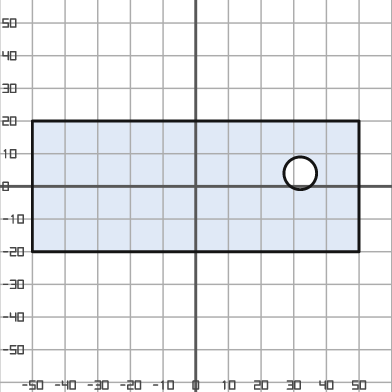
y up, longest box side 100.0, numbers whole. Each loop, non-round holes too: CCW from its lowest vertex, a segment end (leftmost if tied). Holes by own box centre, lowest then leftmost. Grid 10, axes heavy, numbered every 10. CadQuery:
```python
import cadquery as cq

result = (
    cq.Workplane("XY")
    .moveTo(-50.0, -20.0)
    .lineTo(50.0, -20.0)
    .lineTo(50.0, 20.0)
    .lineTo(-50.0, 20.0)
    .close()
    .moveTo(32.0, 4.0)
    .circle(5.0)
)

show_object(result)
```